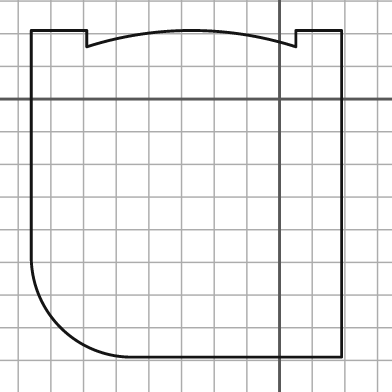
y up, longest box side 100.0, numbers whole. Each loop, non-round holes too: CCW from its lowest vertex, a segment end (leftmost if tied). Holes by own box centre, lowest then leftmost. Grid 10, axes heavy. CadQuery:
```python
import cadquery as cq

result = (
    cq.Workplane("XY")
    .moveTo(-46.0, -79.0)
    .lineTo(19.0, -79.0)
    .lineTo(19.0, 21.0)
    .lineTo(5.0, 21.0)
    .lineTo(5.0, 16.0)
    .threePointArc((-27.0, 21.0), (-59.0, 16.0))
    .lineTo(-59.0, 21.0)
    .lineTo(-76.0, 21.0)
    .lineTo(-76.0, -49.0)
    .threePointArc((-67.0, -70.0), (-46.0, -79.0))
    .close()
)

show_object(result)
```